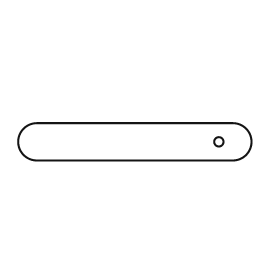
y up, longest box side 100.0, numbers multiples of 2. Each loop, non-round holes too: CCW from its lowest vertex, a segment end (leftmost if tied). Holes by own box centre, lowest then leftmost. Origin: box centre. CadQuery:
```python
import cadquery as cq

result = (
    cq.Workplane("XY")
    .moveTo(-42.0, -8.0)
    .lineTo(42.0, -8.0)
    .threePointArc((50.0, 0.0), (42.0, 8.0))
    .lineTo(-42.0, 8.0)
    .threePointArc((-50.0, 0.0), (-42.0, -8.0))
    .close()
    .moveTo(36.0, 0.0)
    .circle(2.0)
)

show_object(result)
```